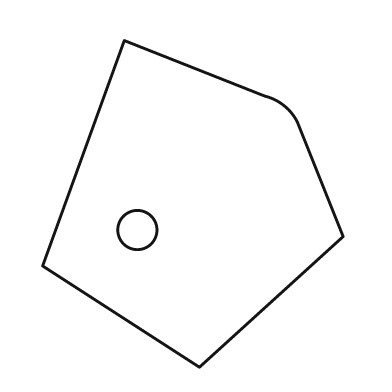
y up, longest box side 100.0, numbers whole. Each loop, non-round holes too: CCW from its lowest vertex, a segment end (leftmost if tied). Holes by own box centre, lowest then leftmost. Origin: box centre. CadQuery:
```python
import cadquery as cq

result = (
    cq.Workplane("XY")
    .moveTo(2.0, -50.0)
    .lineTo(46.0, -10.0)
    .lineTo(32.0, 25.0)
    .threePointArc((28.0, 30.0), (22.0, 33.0))
    .lineTo(-21.0, 50.0)
    .lineTo(-46.0, -19.0)
    .close()
    .moveTo(-17.0, -8.0)
    .circle(6.0)
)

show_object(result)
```